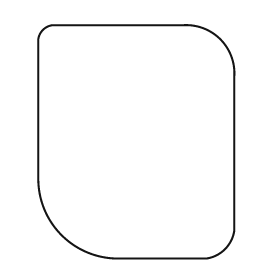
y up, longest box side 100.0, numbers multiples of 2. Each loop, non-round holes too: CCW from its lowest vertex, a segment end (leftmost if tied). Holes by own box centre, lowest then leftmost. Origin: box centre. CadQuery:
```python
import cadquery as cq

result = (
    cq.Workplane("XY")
    .moveTo(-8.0, -50.0)
    .lineTo(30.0, -50.0)
    .threePointArc((38.0, -46.0), (42.0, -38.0))
    .lineTo(42.0, 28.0)
    .threePointArc((36.0, 44.0), (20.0, 50.0))
    .lineTo(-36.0, 50.0)
    .threePointArc((-40.0, 48.0), (-42.0, 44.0))
    .lineTo(-42.0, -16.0)
    .threePointArc((-32.0, -40.0), (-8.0, -50.0))
    .close()
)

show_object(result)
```